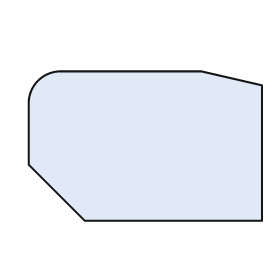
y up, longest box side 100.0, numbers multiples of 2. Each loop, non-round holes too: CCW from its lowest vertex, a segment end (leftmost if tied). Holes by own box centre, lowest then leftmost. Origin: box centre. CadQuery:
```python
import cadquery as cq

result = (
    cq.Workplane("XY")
    .moveTo(-26.0, -32.0)
    .lineTo(50.0, -32.0)
    .lineTo(50.0, 26.0)
    .lineTo(24.0, 32.0)
    .lineTo(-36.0, 32.0)
    .threePointArc((-46.0, 28.0), (-50.0, 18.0))
    .lineTo(-50.0, -8.0)
    .close()
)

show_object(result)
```